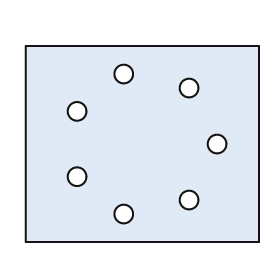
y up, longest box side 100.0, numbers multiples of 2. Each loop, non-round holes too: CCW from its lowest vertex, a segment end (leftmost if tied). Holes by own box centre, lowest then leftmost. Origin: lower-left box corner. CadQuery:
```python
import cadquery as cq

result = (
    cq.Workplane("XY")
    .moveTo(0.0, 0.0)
    .lineTo(100.0, 0.0)
    .lineTo(100.0, 84.0)
    .lineTo(0.0, 84.0)
    .close()
    .moveTo(42.0, 12.0)
    .circle(4.0)
    .moveTo(70.0, 18.0)
    .circle(4.0)
    .moveTo(22.0, 28.0)
    .circle(4.0)
    .moveTo(82.0, 42.0)
    .circle(4.0)
    .moveTo(22.0, 56.0)
    .circle(4.0)
    .moveTo(70.0, 66.0)
    .circle(4.0)
    .moveTo(42.0, 72.0)
    .circle(4.0)
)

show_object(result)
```